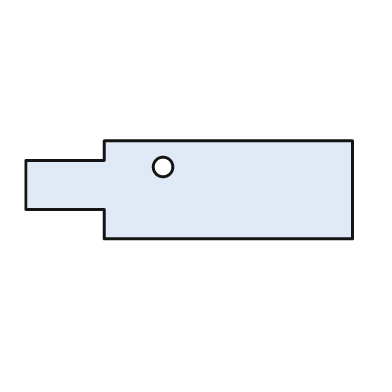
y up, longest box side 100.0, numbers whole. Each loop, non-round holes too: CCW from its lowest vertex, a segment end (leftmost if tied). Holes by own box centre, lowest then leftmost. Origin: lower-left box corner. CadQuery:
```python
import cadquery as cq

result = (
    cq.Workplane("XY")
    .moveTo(24.0, 0.0)
    .lineTo(100.0, 0.0)
    .lineTo(100.0, 30.0)
    .lineTo(24.0, 30.0)
    .lineTo(24.0, 24.0)
    .lineTo(0.0, 24.0)
    .lineTo(0.0, 9.0)
    .lineTo(24.0, 9.0)
    .close()
    .moveTo(42.0, 22.0)
    .circle(3.0)
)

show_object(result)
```